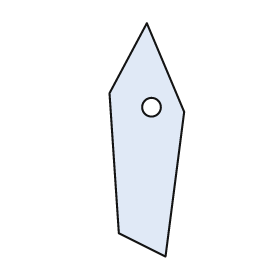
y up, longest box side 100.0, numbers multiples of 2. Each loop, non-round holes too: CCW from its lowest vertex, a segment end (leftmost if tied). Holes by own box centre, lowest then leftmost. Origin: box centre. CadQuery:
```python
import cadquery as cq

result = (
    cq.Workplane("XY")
    .moveTo(8.0, -50.0)
    .lineTo(16.0, 12.0)
    .lineTo(0.0, 50.0)
    .lineTo(-16.0, 20.0)
    .lineTo(-12.0, -40.0)
    .close()
    .moveTo(2.0, 14.0)
    .circle(4.0)
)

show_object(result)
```